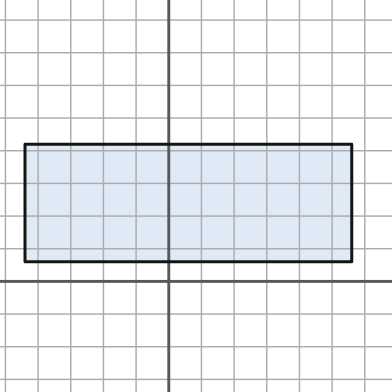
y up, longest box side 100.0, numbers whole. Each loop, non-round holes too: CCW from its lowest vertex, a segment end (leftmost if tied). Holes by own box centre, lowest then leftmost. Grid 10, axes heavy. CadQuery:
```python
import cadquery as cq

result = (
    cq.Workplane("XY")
    .moveTo(-44.0, 6.0)
    .lineTo(56.0, 6.0)
    .lineTo(56.0, 42.0)
    .lineTo(-44.0, 42.0)
    .close()
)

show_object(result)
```